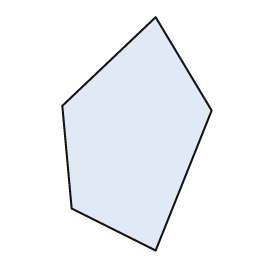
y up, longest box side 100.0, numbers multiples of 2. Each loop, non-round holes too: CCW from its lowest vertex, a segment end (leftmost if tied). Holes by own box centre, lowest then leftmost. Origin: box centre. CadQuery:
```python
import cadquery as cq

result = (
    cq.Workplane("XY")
    .moveTo(8.0, -50.0)
    .lineTo(32.0, 10.0)
    .lineTo(8.0, 50.0)
    .lineTo(-32.0, 12.0)
    .lineTo(-28.0, -32.0)
    .close()
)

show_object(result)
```